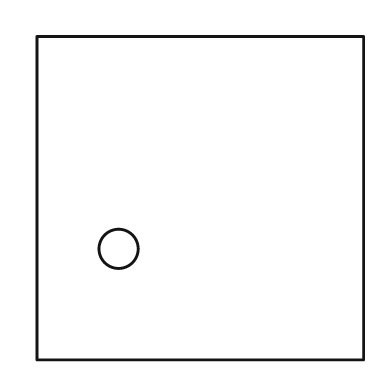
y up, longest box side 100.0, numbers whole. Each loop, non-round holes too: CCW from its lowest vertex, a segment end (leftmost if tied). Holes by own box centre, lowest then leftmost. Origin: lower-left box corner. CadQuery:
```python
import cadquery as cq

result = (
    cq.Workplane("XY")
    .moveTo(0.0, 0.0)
    .lineTo(100.0, 0.0)
    .lineTo(100.0, 99.0)
    .lineTo(0.0, 99.0)
    .close()
    .moveTo(25.0, 34.0)
    .circle(6.0)
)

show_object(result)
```